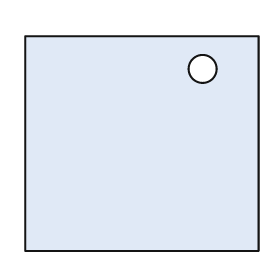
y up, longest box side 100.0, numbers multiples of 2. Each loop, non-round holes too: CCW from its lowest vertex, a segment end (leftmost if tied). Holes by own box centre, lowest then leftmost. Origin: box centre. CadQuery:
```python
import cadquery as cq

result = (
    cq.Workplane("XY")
    .moveTo(-50.0, -46.0)
    .lineTo(50.0, -46.0)
    .lineTo(50.0, 46.0)
    .lineTo(-50.0, 46.0)
    .close()
    .moveTo(26.0, 32.0)
    .circle(6.0)
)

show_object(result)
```